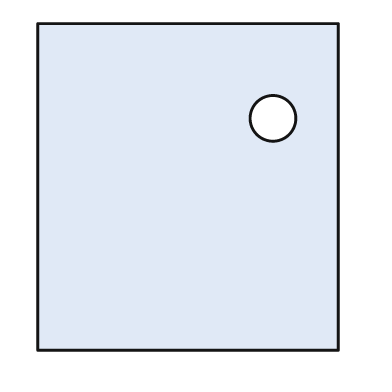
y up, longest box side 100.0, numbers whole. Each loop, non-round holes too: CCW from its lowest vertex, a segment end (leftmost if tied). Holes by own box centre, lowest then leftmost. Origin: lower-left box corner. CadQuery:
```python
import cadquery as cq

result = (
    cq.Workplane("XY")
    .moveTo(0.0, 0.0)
    .lineTo(92.0, 0.0)
    .lineTo(92.0, 100.0)
    .lineTo(0.0, 100.0)
    .close()
    .moveTo(72.0, 71.0)
    .circle(7.0)
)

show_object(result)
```